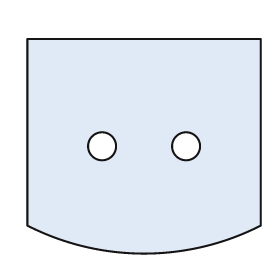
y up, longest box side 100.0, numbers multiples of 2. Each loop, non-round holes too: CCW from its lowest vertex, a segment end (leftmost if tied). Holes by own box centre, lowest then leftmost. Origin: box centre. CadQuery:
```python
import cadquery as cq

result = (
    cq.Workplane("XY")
    .moveTo(-50.0, -34.0)
    .threePointArc((0.0, -46.0), (50.0, -34.0))
    .lineTo(50.0, 46.0)
    .lineTo(-50.0, 46.0)
    .close()
    .moveTo(-18.0, 0.0)
    .circle(6.0)
    .moveTo(18.0, 0.0)
    .circle(6.0)
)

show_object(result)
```